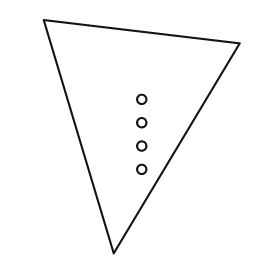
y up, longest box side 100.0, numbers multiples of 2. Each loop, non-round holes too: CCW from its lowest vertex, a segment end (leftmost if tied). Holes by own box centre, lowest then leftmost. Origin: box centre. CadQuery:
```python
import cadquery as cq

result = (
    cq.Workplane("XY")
    .moveTo(-12.0, -50.0)
    .lineTo(42.0, 40.0)
    .lineTo(-42.0, 50.0)
    .close()
    .moveTo(0.0, -14.0)
    .circle(2.0)
    .moveTo(0.0, -4.0)
    .circle(2.0)
    .moveTo(0.0, 6.0)
    .circle(2.0)
    .moveTo(0.0, 16.0)
    .circle(2.0)
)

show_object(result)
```